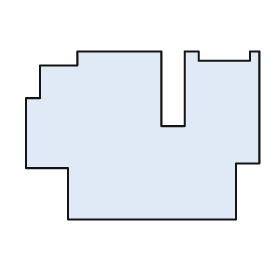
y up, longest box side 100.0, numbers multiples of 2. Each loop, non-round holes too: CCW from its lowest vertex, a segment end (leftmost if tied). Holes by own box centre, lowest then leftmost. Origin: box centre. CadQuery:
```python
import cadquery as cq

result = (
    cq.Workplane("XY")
    .moveTo(-32.0, -36.0)
    .lineTo(40.0, -36.0)
    .lineTo(40.0, -12.0)
    .lineTo(50.0, -12.0)
    .lineTo(50.0, 36.0)
    .lineTo(46.0, 36.0)
    .lineTo(46.0, 32.0)
    .lineTo(24.0, 32.0)
    .lineTo(24.0, 36.0)
    .lineTo(18.0, 36.0)
    .lineTo(18.0, 4.0)
    .lineTo(8.0, 4.0)
    .lineTo(8.0, 36.0)
    .lineTo(-28.0, 36.0)
    .lineTo(-28.0, 30.0)
    .lineTo(-44.0, 30.0)
    .lineTo(-44.0, 16.0)
    .lineTo(-50.0, 16.0)
    .lineTo(-50.0, -14.0)
    .lineTo(-32.0, -14.0)
    .close()
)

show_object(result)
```